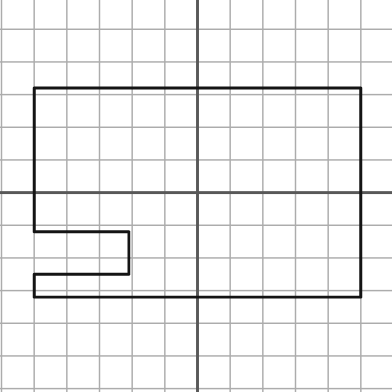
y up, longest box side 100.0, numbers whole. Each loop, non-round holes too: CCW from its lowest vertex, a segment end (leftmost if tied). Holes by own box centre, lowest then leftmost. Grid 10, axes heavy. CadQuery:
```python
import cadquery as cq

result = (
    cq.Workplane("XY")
    .moveTo(-50.0, -32.0)
    .lineTo(50.0, -32.0)
    .lineTo(50.0, 32.0)
    .lineTo(-50.0, 32.0)
    .lineTo(-50.0, -12.0)
    .lineTo(-21.0, -12.0)
    .lineTo(-21.0, -25.0)
    .lineTo(-50.0, -25.0)
    .close()
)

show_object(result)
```